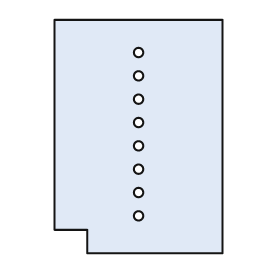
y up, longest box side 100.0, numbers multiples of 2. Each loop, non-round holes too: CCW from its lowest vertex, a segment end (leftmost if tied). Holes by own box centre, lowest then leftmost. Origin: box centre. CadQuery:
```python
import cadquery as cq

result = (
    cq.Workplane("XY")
    .moveTo(-22.0, -50.0)
    .lineTo(36.0, -50.0)
    .lineTo(36.0, 50.0)
    .lineTo(-36.0, 50.0)
    .lineTo(-36.0, -40.0)
    .lineTo(-22.0, -40.0)
    .close()
    .moveTo(0.0, -34.0)
    .circle(2.0)
    .moveTo(0.0, -24.0)
    .circle(2.0)
    .moveTo(0.0, -14.0)
    .circle(2.0)
    .moveTo(0.0, -4.0)
    .circle(2.0)
    .moveTo(0.0, 6.0)
    .circle(2.0)
    .moveTo(0.0, 16.0)
    .circle(2.0)
    .moveTo(0.0, 26.0)
    .circle(2.0)
    .moveTo(0.0, 36.0)
    .circle(2.0)
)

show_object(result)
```